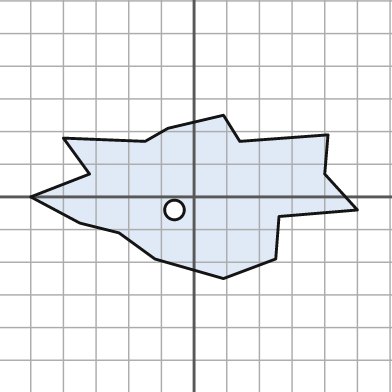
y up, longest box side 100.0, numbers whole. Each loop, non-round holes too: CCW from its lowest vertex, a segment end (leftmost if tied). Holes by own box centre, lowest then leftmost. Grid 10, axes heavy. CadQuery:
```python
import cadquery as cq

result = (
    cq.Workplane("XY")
    .moveTo(9.0, -25.0)
    .lineTo(25.0, -19.0)
    .lineTo(26.0, -6.0)
    .lineTo(50.0, -4.0)
    .lineTo(40.0, 7.0)
    .lineTo(41.0, 19.0)
    .lineTo(14.0, 17.0)
    .lineTo(9.0, 25.0)
    .lineTo(-8.0, 21.0)
    .lineTo(-15.0, 17.0)
    .lineTo(-40.0, 18.0)
    .lineTo(-32.0, 7.0)
    .lineTo(-50.0, 0.0)
    .lineTo(-35.0, -8.0)
    .lineTo(-23.0, -11.0)
    .lineTo(-12.0, -19.0)
    .close()
    .moveTo(-6.0, -4.0)
    .circle(3.0)
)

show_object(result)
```